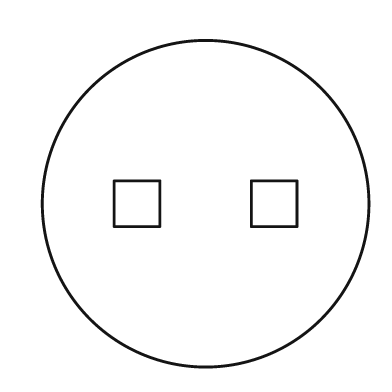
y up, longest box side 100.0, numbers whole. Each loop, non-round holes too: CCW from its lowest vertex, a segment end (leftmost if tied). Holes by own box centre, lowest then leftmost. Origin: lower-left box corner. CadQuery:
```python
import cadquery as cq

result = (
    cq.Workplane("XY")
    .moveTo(50.0, 50.0)
    .circle(50.0)
    .moveTo(22.0, 43.0)
    .lineTo(36.0, 43.0)
    .lineTo(36.0, 57.0)
    .lineTo(22.0, 57.0)
    .close()
    .moveTo(64.0, 43.0)
    .lineTo(78.0, 43.0)
    .lineTo(78.0, 57.0)
    .lineTo(64.0, 57.0)
    .close()
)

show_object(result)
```